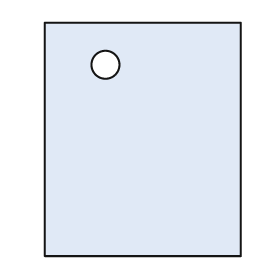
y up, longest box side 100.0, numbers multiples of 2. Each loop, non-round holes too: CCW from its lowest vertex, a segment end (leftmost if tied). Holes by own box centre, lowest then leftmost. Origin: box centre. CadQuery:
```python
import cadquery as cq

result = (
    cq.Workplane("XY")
    .moveTo(-42.0, -50.0)
    .lineTo(42.0, -50.0)
    .lineTo(42.0, 50.0)
    .lineTo(-42.0, 50.0)
    .close()
    .moveTo(-16.0, 32.0)
    .circle(6.0)
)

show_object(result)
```